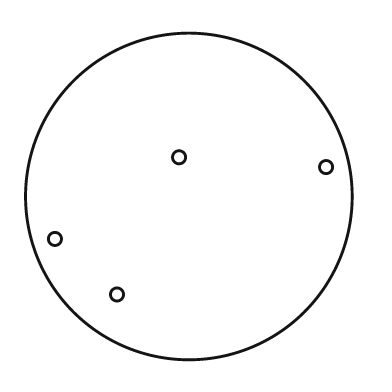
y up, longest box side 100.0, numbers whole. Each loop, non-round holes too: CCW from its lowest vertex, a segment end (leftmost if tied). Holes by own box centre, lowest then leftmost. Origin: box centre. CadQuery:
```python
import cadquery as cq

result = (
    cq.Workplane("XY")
    .moveTo(0.0, 0.0)
    .circle(50.0)
    .moveTo(-22.0, -30.0)
    .circle(2.0)
    .moveTo(-41.0, -13.0)
    .circle(2.0)
    .moveTo(42.0, 9.0)
    .circle(2.0)
    .moveTo(-3.0, 12.0)
    .circle(2.0)
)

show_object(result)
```